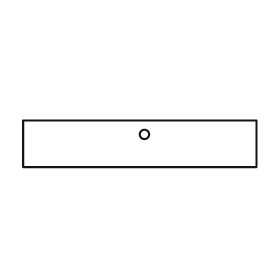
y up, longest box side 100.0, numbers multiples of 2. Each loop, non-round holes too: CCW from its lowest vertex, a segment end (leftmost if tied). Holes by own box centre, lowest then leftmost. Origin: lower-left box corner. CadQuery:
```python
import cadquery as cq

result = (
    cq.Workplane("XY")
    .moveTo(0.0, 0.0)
    .lineTo(100.0, 0.0)
    .lineTo(100.0, 20.0)
    .lineTo(0.0, 20.0)
    .close()
    .moveTo(52.0, 14.0)
    .circle(2.0)
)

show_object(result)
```